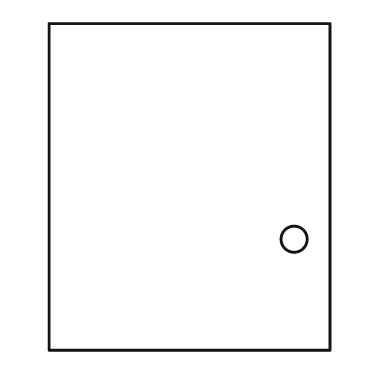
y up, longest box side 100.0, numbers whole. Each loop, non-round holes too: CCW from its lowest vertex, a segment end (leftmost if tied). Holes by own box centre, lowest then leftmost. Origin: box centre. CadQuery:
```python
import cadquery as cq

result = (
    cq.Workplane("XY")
    .moveTo(-43.0, -50.0)
    .lineTo(43.0, -50.0)
    .lineTo(43.0, 50.0)
    .lineTo(-43.0, 50.0)
    .close()
    .moveTo(32.0, -16.0)
    .circle(4.0)
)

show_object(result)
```